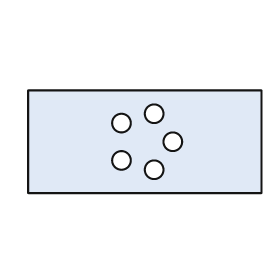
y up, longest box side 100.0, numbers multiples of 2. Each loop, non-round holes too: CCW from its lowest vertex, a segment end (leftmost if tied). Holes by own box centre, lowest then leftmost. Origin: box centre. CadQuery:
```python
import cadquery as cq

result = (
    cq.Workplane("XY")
    .moveTo(-50.0, -22.0)
    .lineTo(50.0, -22.0)
    .lineTo(50.0, 22.0)
    .lineTo(-50.0, 22.0)
    .close()
    .moveTo(4.0, -12.0)
    .circle(4.0)
    .moveTo(-10.0, -8.0)
    .circle(4.0)
    .moveTo(12.0, 0.0)
    .circle(4.0)
    .moveTo(-10.0, 8.0)
    .circle(4.0)
    .moveTo(4.0, 12.0)
    .circle(4.0)
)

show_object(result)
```